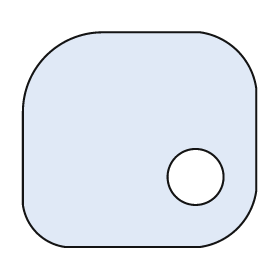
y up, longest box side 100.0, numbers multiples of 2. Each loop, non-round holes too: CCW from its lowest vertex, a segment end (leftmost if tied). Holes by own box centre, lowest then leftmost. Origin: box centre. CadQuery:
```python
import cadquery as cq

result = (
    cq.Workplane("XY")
    .moveTo(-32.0, -46.0)
    .lineTo(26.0, -46.0)
    .threePointArc((42.0, -38.0), (50.0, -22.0))
    .lineTo(50.0, 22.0)
    .threePointArc((42.0, 38.0), (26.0, 46.0))
    .lineTo(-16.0, 46.0)
    .threePointArc((-40.0, 36.0), (-50.0, 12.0))
    .lineTo(-50.0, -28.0)
    .threePointArc((-44.0, -40.0), (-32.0, -46.0))
    .close()
    .moveTo(24.0, -16.0)
    .circle(12.0)
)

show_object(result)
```